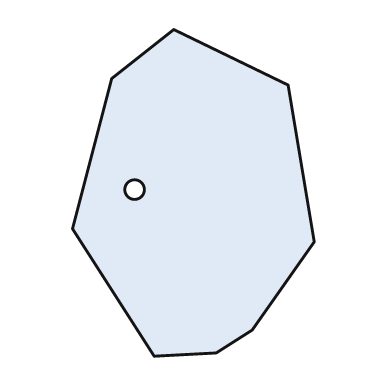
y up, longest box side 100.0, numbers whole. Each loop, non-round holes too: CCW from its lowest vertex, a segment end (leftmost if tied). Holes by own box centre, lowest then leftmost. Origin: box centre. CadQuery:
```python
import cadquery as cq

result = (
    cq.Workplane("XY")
    .moveTo(-12.0, -50.0)
    .lineTo(7.0, -49.0)
    .lineTo(18.0, -42.0)
    .lineTo(37.0, -15.0)
    .lineTo(29.0, 33.0)
    .lineTo(-6.0, 50.0)
    .lineTo(-25.0, 35.0)
    .lineTo(-37.0, -11.0)
    .close()
    .moveTo(-18.0, 1.0)
    .circle(3.0)
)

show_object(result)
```